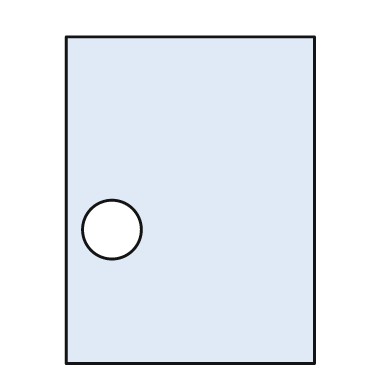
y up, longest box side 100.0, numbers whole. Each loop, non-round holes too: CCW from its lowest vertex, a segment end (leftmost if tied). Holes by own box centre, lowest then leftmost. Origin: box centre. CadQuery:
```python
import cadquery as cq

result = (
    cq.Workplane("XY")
    .moveTo(-38.0, -50.0)
    .lineTo(38.0, -50.0)
    .lineTo(38.0, 50.0)
    .lineTo(-38.0, 50.0)
    .close()
    .moveTo(-24.0, -9.0)
    .circle(9.0)
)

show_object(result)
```